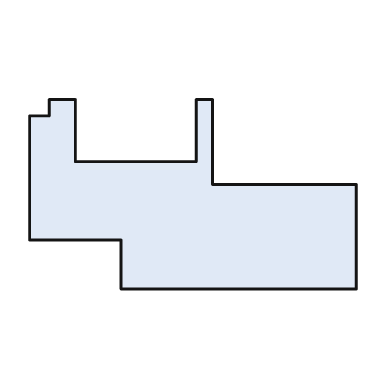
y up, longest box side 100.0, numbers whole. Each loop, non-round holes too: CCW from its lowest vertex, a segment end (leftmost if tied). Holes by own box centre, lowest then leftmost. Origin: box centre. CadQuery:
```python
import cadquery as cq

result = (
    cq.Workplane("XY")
    .moveTo(-22.0, -29.0)
    .lineTo(50.0, -29.0)
    .lineTo(50.0, 3.0)
    .lineTo(6.0, 3.0)
    .lineTo(6.0, 29.0)
    .lineTo(1.0, 29.0)
    .lineTo(1.0, 10.0)
    .lineTo(-36.0, 10.0)
    .lineTo(-36.0, 29.0)
    .lineTo(-44.0, 29.0)
    .lineTo(-44.0, 24.0)
    .lineTo(-50.0, 24.0)
    .lineTo(-50.0, -14.0)
    .lineTo(-22.0, -14.0)
    .close()
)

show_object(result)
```